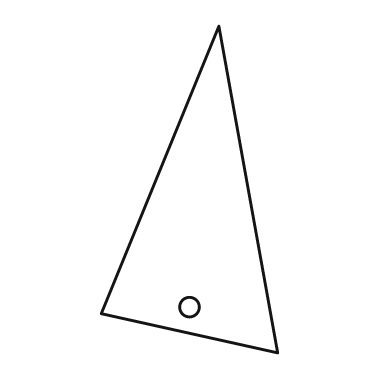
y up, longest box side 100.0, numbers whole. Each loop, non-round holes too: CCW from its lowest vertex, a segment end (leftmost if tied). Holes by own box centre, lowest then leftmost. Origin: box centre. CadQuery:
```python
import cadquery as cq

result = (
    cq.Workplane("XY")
    .moveTo(27.0, -50.0)
    .lineTo(9.0, 50.0)
    .lineTo(-27.0, -38.0)
    .close()
    .moveTo(0.0, -36.0)
    .circle(3.0)
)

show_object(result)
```